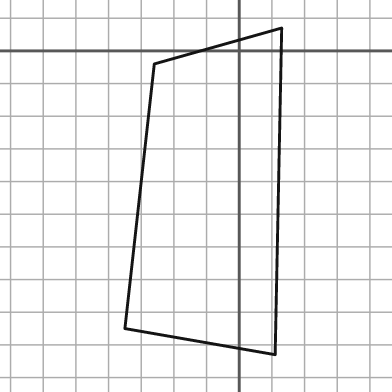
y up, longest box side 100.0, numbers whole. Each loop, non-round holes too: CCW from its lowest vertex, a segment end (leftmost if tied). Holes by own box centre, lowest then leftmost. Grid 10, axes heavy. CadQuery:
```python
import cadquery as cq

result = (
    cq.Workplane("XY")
    .moveTo(11.0, -93.0)
    .lineTo(13.0, 7.0)
    .lineTo(-26.0, -4.0)
    .lineTo(-35.0, -85.0)
    .close()
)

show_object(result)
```